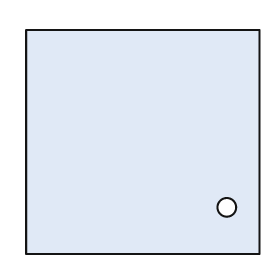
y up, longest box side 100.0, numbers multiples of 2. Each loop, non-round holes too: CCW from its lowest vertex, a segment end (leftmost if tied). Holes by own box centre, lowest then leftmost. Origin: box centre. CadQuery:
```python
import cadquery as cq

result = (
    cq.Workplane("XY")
    .moveTo(-50.0, -48.0)
    .lineTo(50.0, -48.0)
    .lineTo(50.0, 48.0)
    .lineTo(-50.0, 48.0)
    .close()
    .moveTo(36.0, -28.0)
    .circle(4.0)
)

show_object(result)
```